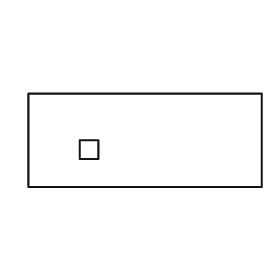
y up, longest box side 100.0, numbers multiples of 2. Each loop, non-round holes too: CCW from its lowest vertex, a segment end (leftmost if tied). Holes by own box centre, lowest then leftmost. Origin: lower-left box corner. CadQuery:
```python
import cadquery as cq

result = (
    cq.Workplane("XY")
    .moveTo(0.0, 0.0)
    .lineTo(100.0, 0.0)
    .lineTo(100.0, 40.0)
    .lineTo(0.0, 40.0)
    .close()
    .moveTo(22.0, 12.0)
    .lineTo(30.0, 12.0)
    .lineTo(30.0, 20.0)
    .lineTo(22.0, 20.0)
    .close()
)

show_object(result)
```